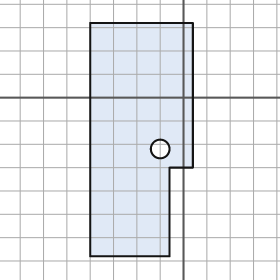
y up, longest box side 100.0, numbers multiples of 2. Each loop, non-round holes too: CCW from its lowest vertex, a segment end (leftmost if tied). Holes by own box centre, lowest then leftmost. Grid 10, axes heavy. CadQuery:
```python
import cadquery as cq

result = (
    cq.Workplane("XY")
    .moveTo(-40.0, -68.0)
    .lineTo(-6.0, -68.0)
    .lineTo(-6.0, -30.0)
    .lineTo(4.0, -30.0)
    .lineTo(4.0, 32.0)
    .lineTo(-40.0, 32.0)
    .close()
    .moveTo(-10.0, -22.0)
    .circle(4.0)
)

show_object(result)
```